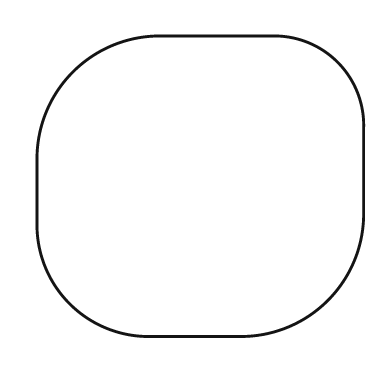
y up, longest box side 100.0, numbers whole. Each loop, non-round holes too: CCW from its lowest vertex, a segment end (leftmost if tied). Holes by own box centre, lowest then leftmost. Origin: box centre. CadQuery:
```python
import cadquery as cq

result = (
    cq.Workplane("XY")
    .moveTo(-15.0, -46.0)
    .lineTo(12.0, -46.0)
    .threePointArc((39.0, -35.0), (50.0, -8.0))
    .lineTo(50.0, 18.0)
    .threePointArc((42.0, 38.0), (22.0, 46.0))
    .lineTo(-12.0, 46.0)
    .threePointArc((-39.0, 35.0), (-50.0, 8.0))
    .lineTo(-50.0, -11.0)
    .threePointArc((-40.0, -36.0), (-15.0, -46.0))
    .close()
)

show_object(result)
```